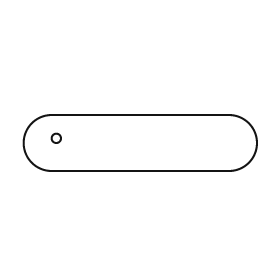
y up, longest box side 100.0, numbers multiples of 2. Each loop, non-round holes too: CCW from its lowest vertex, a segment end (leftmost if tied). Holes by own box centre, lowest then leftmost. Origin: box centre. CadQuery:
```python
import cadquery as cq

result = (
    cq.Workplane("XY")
    .moveTo(-38.0, -12.0)
    .lineTo(38.0, -12.0)
    .threePointArc((50.0, 0.0), (38.0, 12.0))
    .lineTo(-38.0, 12.0)
    .threePointArc((-50.0, 0.0), (-38.0, -12.0))
    .close()
    .moveTo(-36.0, 2.0)
    .circle(2.0)
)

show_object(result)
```